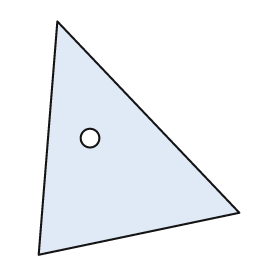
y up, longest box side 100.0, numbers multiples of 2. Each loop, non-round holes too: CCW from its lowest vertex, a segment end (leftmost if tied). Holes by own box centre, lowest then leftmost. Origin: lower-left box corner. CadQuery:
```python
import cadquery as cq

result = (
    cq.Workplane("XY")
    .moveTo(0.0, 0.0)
    .lineTo(86.0, 18.0)
    .lineTo(8.0, 100.0)
    .close()
    .moveTo(22.0, 50.0)
    .circle(4.0)
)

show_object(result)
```